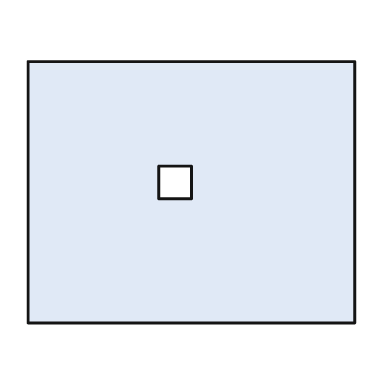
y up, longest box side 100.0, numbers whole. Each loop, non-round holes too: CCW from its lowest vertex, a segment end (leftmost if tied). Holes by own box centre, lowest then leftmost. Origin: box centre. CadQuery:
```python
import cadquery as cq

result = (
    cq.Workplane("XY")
    .moveTo(-50.0, -40.0)
    .lineTo(50.0, -40.0)
    .lineTo(50.0, 40.0)
    .lineTo(-50.0, 40.0)
    .close()
    .moveTo(-10.0, -2.0)
    .lineTo(0.0, -2.0)
    .lineTo(0.0, 8.0)
    .lineTo(-10.0, 8.0)
    .close()
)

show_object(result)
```